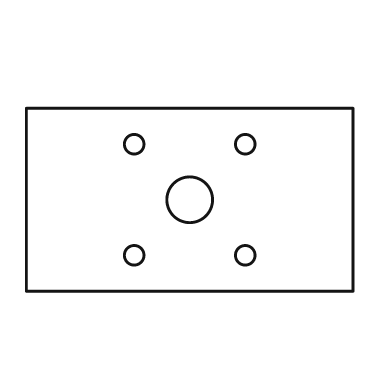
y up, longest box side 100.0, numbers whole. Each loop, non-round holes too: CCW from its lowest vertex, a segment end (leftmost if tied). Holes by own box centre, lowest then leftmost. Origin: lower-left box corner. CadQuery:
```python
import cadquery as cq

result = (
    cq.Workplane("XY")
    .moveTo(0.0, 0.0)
    .lineTo(100.0, 0.0)
    .lineTo(100.0, 56.0)
    .lineTo(0.0, 56.0)
    .close()
    .moveTo(33.0, 11.0)
    .circle(3.0)
    .moveTo(67.0, 11.0)
    .circle(3.0)
    .moveTo(50.0, 28.0)
    .circle(7.0)
    .moveTo(33.0, 45.0)
    .circle(3.0)
    .moveTo(67.0, 45.0)
    .circle(3.0)
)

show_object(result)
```